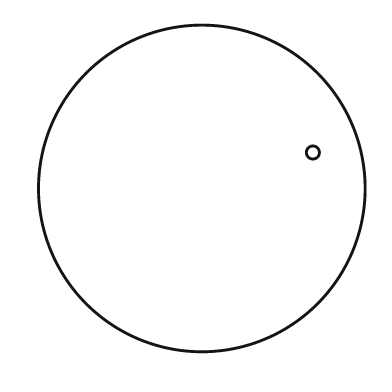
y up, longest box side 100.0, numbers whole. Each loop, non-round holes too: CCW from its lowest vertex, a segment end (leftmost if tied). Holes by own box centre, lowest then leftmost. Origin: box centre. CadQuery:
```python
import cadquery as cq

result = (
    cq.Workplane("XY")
    .moveTo(0.0, 0.0)
    .circle(50.0)
    .moveTo(34.0, 11.0)
    .circle(2.0)
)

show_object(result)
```